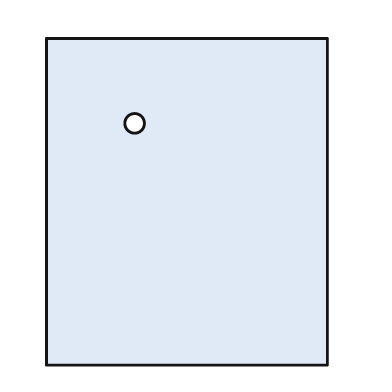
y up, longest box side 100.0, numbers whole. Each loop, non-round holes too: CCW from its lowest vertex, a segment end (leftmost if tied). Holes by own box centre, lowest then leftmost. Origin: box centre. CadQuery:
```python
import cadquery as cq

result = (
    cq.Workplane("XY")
    .moveTo(-43.0, -50.0)
    .lineTo(43.0, -50.0)
    .lineTo(43.0, 50.0)
    .lineTo(-43.0, 50.0)
    .close()
    .moveTo(-16.0, 24.0)
    .circle(3.0)
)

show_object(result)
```